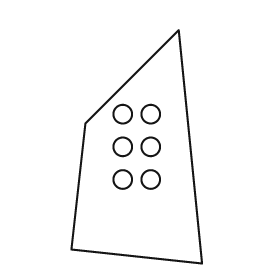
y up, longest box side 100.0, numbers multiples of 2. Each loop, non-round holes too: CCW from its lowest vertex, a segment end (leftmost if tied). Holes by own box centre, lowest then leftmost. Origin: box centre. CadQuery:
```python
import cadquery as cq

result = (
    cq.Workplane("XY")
    .moveTo(28.0, -50.0)
    .lineTo(18.0, 50.0)
    .lineTo(-22.0, 10.0)
    .lineTo(-28.0, -44.0)
    .close()
    .moveTo(-6.0, -14.0)
    .circle(4.0)
    .moveTo(6.0, -14.0)
    .circle(4.0)
    .moveTo(-6.0, 0.0)
    .circle(4.0)
    .moveTo(6.0, 0.0)
    .circle(4.0)
    .moveTo(-6.0, 14.0)
    .circle(4.0)
    .moveTo(6.0, 14.0)
    .circle(4.0)
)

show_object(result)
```